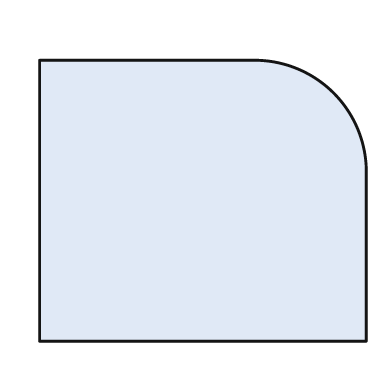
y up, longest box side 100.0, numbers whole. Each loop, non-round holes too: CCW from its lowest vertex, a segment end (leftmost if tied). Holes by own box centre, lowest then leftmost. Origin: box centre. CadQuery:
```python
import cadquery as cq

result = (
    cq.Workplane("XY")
    .moveTo(-50.0, -43.0)
    .lineTo(50.0, -43.0)
    .lineTo(50.0, 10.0)
    .threePointArc((40.0, 33.0), (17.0, 43.0))
    .lineTo(-50.0, 43.0)
    .close()
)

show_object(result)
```